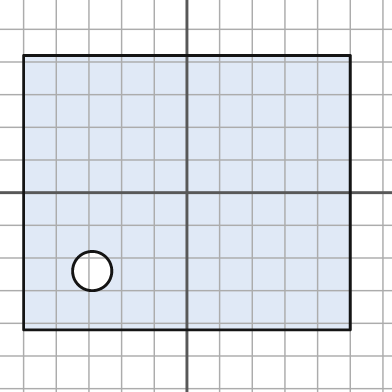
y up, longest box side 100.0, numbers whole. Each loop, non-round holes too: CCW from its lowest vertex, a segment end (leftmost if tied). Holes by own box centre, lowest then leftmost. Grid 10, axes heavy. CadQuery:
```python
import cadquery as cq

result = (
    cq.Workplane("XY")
    .moveTo(-50.0, -42.0)
    .lineTo(50.0, -42.0)
    .lineTo(50.0, 42.0)
    .lineTo(-50.0, 42.0)
    .close()
    .moveTo(-29.0, -24.0)
    .circle(6.0)
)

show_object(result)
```